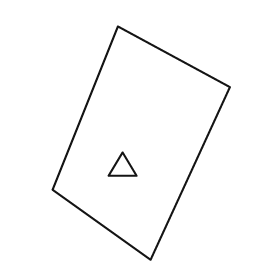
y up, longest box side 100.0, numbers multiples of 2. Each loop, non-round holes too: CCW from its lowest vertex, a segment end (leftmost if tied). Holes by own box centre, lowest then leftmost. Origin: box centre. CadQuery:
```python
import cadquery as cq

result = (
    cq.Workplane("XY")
    .moveTo(4.0, -50.0)
    .lineTo(38.0, 24.0)
    .lineTo(-10.0, 50.0)
    .lineTo(-38.0, -20.0)
    .close()
    .moveTo(-14.0, -14.0)
    .lineTo(-2.0, -14.0)
    .lineTo(-8.0, -4.0)
    .close()
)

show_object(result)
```